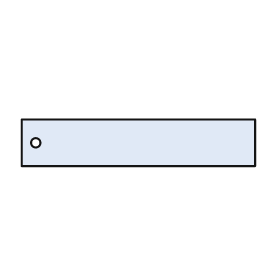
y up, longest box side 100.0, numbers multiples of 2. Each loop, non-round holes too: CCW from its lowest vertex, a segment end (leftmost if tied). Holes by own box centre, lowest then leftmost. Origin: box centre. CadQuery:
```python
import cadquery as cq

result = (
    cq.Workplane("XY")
    .moveTo(-50.0, -10.0)
    .lineTo(50.0, -10.0)
    .lineTo(50.0, 10.0)
    .lineTo(-50.0, 10.0)
    .close()
    .moveTo(-44.0, 0.0)
    .circle(2.0)
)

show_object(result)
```